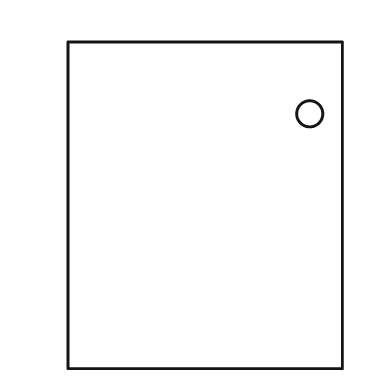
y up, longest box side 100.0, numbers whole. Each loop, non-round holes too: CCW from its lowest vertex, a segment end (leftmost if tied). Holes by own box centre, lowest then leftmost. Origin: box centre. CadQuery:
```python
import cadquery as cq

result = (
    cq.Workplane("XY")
    .moveTo(-42.0, -50.0)
    .lineTo(42.0, -50.0)
    .lineTo(42.0, 50.0)
    .lineTo(-42.0, 50.0)
    .close()
    .moveTo(32.0, 28.0)
    .circle(4.0)
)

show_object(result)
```